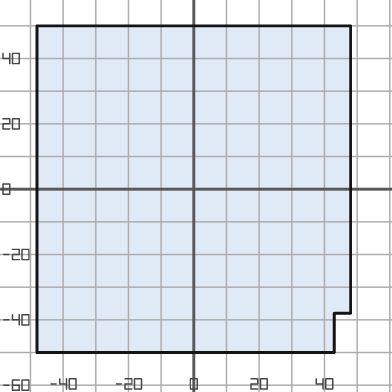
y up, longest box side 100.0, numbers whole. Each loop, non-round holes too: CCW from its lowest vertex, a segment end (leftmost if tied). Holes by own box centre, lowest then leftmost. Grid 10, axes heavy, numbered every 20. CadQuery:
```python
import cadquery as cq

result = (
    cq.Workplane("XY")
    .moveTo(-48.0, -50.0)
    .lineTo(43.0, -50.0)
    .lineTo(43.0, -38.0)
    .lineTo(48.0, -38.0)
    .lineTo(48.0, 50.0)
    .lineTo(-48.0, 50.0)
    .close()
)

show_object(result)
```